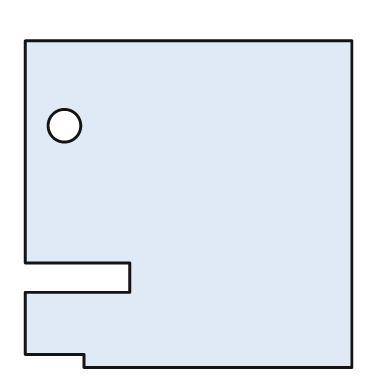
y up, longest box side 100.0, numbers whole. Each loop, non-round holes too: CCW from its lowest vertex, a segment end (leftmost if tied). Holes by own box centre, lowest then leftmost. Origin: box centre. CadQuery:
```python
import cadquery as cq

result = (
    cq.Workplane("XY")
    .moveTo(-32.0, -50.0)
    .lineTo(50.0, -50.0)
    .lineTo(50.0, 50.0)
    .lineTo(-50.0, 50.0)
    .lineTo(-50.0, -18.0)
    .lineTo(-18.0, -18.0)
    .lineTo(-18.0, -27.0)
    .lineTo(-50.0, -27.0)
    .lineTo(-50.0, -46.0)
    .lineTo(-32.0, -46.0)
    .close()
    .moveTo(-38.0, 24.0)
    .circle(5.0)
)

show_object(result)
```